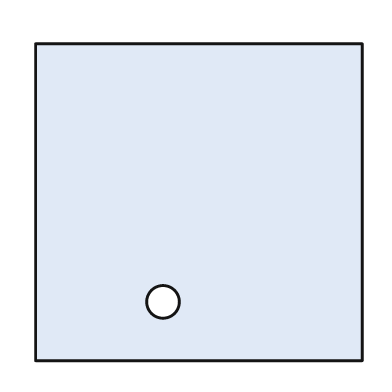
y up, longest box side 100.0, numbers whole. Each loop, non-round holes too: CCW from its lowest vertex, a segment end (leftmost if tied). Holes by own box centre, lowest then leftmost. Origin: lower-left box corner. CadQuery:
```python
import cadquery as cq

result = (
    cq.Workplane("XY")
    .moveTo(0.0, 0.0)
    .lineTo(100.0, 0.0)
    .lineTo(100.0, 97.0)
    .lineTo(0.0, 97.0)
    .close()
    .moveTo(39.0, 18.0)
    .circle(5.0)
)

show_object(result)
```